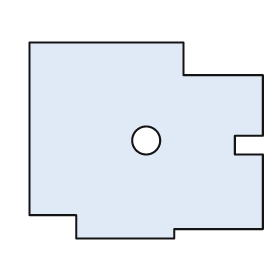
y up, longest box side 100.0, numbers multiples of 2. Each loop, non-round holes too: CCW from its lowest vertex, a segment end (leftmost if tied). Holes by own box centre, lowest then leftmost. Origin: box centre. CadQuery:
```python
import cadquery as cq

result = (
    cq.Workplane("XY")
    .moveTo(-30.0, -42.0)
    .lineTo(12.0, -42.0)
    .lineTo(12.0, -38.0)
    .lineTo(50.0, -38.0)
    .lineTo(50.0, -6.0)
    .lineTo(38.0, -6.0)
    .lineTo(38.0, 2.0)
    .lineTo(50.0, 2.0)
    .lineTo(50.0, 28.0)
    .lineTo(16.0, 28.0)
    .lineTo(16.0, 42.0)
    .lineTo(-50.0, 42.0)
    .lineTo(-50.0, -32.0)
    .lineTo(-30.0, -32.0)
    .close()
    .moveTo(0.0, 0.0)
    .circle(6.0)
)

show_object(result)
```